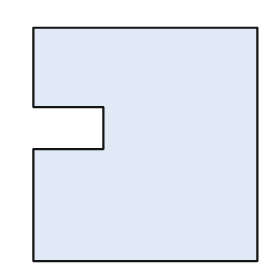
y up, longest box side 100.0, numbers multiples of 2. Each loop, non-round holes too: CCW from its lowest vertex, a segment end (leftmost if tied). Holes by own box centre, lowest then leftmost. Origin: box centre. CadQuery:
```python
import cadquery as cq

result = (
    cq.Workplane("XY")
    .moveTo(-48.0, -50.0)
    .lineTo(48.0, -50.0)
    .lineTo(48.0, 50.0)
    .lineTo(-48.0, 50.0)
    .lineTo(-48.0, 16.0)
    .lineTo(-18.0, 16.0)
    .lineTo(-18.0, -2.0)
    .lineTo(-48.0, -2.0)
    .close()
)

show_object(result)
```